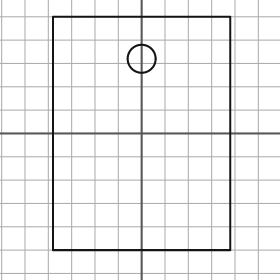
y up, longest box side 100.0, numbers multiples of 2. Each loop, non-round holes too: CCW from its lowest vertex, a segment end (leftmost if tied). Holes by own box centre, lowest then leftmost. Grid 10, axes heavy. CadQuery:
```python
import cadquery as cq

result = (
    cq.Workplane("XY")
    .moveTo(-38.0, -50.0)
    .lineTo(38.0, -50.0)
    .lineTo(38.0, 50.0)
    .lineTo(-38.0, 50.0)
    .close()
    .moveTo(0.0, 32.0)
    .circle(6.0)
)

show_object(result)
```